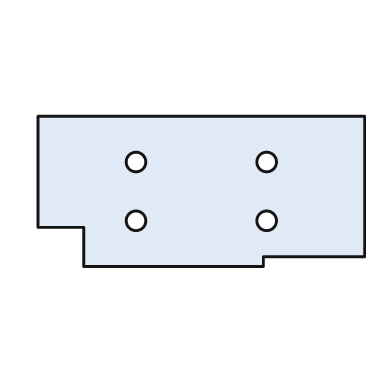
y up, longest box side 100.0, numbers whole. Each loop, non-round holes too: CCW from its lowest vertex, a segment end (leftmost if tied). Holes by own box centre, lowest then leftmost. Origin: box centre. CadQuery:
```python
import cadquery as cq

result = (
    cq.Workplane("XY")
    .moveTo(-36.0, -23.0)
    .lineTo(19.0, -23.0)
    .lineTo(19.0, -20.0)
    .lineTo(50.0, -20.0)
    .lineTo(50.0, 23.0)
    .lineTo(-50.0, 23.0)
    .lineTo(-50.0, -11.0)
    .lineTo(-36.0, -11.0)
    .close()
    .moveTo(-20.0, -9.0)
    .circle(3.0)
    .moveTo(20.0, -9.0)
    .circle(3.0)
    .moveTo(-20.0, 9.0)
    .circle(3.0)
    .moveTo(20.0, 9.0)
    .circle(3.0)
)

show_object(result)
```